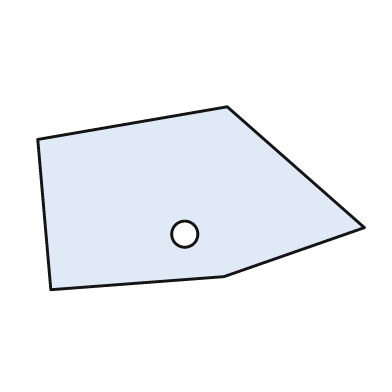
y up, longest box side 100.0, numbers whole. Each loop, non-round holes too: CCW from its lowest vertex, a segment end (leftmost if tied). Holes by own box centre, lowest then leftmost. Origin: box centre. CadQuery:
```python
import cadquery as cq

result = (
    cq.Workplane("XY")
    .moveTo(-46.0, -28.0)
    .lineTo(7.0, -24.0)
    .lineTo(50.0, -9.0)
    .lineTo(8.0, 28.0)
    .lineTo(-50.0, 18.0)
    .close()
    .moveTo(-5.0, -11.0)
    .circle(4.0)
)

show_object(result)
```